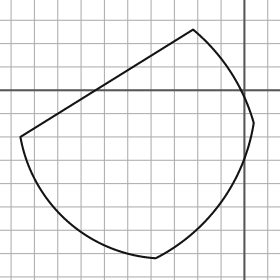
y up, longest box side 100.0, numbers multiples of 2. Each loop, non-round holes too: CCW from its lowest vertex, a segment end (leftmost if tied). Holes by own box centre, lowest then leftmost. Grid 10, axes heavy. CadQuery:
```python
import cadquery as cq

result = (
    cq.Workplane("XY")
    .moveTo(-38.0, -72.0)
    .threePointArc((-10.0, -48.0), (4.0, -14.0))
    .threePointArc((-6.0, 8.0), (-22.0, 26.0))
    .lineTo(-96.0, -20.0)
    .threePointArc((-76.0, -56.0), (-38.0, -72.0))
    .close()
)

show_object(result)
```